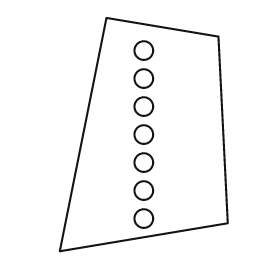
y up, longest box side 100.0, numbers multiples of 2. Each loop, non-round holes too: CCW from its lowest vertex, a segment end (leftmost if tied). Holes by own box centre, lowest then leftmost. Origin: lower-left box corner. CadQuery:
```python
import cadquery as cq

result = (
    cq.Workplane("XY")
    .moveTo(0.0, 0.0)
    .lineTo(72.0, 12.0)
    .lineTo(68.0, 92.0)
    .lineTo(20.0, 100.0)
    .close()
    .moveTo(36.0, 14.0)
    .circle(4.0)
    .moveTo(36.0, 26.0)
    .circle(4.0)
    .moveTo(36.0, 38.0)
    .circle(4.0)
    .moveTo(36.0, 50.0)
    .circle(4.0)
    .moveTo(36.0, 62.0)
    .circle(4.0)
    .moveTo(36.0, 74.0)
    .circle(4.0)
    .moveTo(36.0, 86.0)
    .circle(4.0)
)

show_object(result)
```